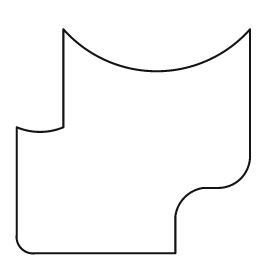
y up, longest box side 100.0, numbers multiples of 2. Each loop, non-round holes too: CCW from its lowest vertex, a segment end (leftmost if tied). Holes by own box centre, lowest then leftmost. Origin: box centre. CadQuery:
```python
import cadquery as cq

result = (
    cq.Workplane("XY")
    .moveTo(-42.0, -48.0)
    .lineTo(18.0, -48.0)
    .lineTo(18.0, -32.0)
    .threePointArc((22.0, -24.0), (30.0, -20.0))
    .lineTo(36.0, -20.0)
    .threePointArc((46.0, -16.0), (50.0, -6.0))
    .lineTo(50.0, 48.0)
    .threePointArc((10.0, 30.0), (-30.0, 48.0))
    .lineTo(-30.0, 6.0)
    .threePointArc((-40.0, 4.0), (-50.0, 6.0))
    .lineTo(-50.0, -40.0)
    .threePointArc((-48.0, -46.0), (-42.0, -48.0))
    .close()
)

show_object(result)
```